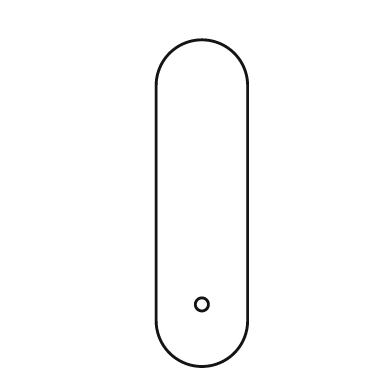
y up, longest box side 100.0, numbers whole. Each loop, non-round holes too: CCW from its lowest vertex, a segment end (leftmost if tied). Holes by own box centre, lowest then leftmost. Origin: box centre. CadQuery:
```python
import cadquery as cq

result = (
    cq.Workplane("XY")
    .moveTo(-14.0, -36.0)
    .threePointArc((0.0, -50.0), (14.0, -36.0))
    .lineTo(14.0, 36.0)
    .threePointArc((0.0, 50.0), (-14.0, 36.0))
    .close()
    .moveTo(0.0, -31.0)
    .circle(2.0)
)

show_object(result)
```